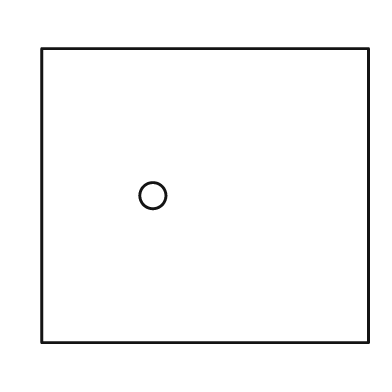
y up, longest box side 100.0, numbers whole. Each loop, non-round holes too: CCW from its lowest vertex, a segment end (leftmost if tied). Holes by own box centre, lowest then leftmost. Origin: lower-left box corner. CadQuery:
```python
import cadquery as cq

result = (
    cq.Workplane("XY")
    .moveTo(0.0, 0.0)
    .lineTo(100.0, 0.0)
    .lineTo(100.0, 90.0)
    .lineTo(0.0, 90.0)
    .close()
    .moveTo(34.0, 45.0)
    .circle(4.0)
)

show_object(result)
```